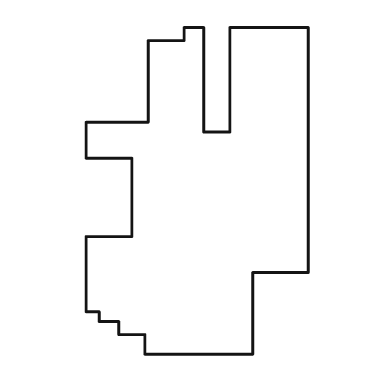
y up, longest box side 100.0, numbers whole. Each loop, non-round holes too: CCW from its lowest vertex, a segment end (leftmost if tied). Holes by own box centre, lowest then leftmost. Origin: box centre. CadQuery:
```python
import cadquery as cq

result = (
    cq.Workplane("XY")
    .moveTo(-16.0, -50.0)
    .lineTo(17.0, -50.0)
    .lineTo(17.0, -25.0)
    .lineTo(34.0, -25.0)
    .lineTo(34.0, 50.0)
    .lineTo(10.0, 50.0)
    .lineTo(10.0, 18.0)
    .lineTo(2.0, 18.0)
    .lineTo(2.0, 50.0)
    .lineTo(-4.0, 50.0)
    .lineTo(-4.0, 46.0)
    .lineTo(-15.0, 46.0)
    .lineTo(-15.0, 21.0)
    .lineTo(-34.0, 21.0)
    .lineTo(-34.0, 10.0)
    .lineTo(-20.0, 10.0)
    .lineTo(-20.0, -14.0)
    .lineTo(-34.0, -14.0)
    .lineTo(-34.0, -37.0)
    .lineTo(-30.0, -37.0)
    .lineTo(-30.0, -40.0)
    .lineTo(-24.0, -40.0)
    .lineTo(-24.0, -44.0)
    .lineTo(-16.0, -44.0)
    .close()
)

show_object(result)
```